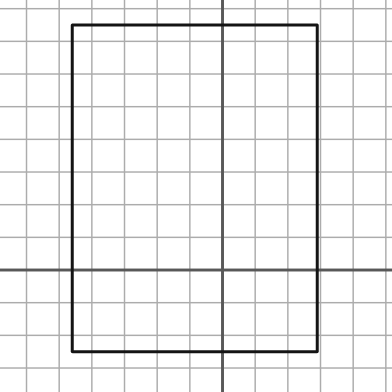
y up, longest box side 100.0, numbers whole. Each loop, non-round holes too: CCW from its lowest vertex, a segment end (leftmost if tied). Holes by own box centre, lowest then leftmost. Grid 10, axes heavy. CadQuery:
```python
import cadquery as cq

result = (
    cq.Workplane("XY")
    .moveTo(-46.0, -25.0)
    .lineTo(29.0, -25.0)
    .lineTo(29.0, 75.0)
    .lineTo(-46.0, 75.0)
    .close()
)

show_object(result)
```